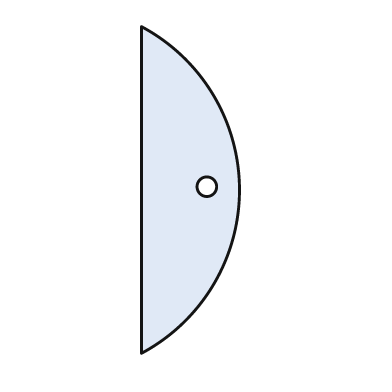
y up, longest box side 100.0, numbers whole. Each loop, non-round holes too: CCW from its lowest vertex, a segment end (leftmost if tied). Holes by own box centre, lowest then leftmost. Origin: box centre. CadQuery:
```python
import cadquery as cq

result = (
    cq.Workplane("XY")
    .moveTo(-15.0, -50.0)
    .threePointArc((15.0, 0.0), (-15.0, 50.0))
    .close()
    .moveTo(5.0, 1.0)
    .circle(3.0)
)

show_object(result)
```